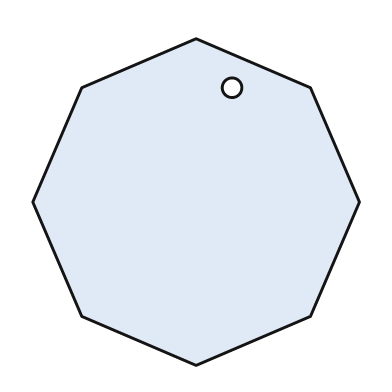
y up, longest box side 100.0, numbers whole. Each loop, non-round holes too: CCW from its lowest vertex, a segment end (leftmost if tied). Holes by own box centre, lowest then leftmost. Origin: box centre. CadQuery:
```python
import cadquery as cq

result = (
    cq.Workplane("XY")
    .moveTo(0.0, -50.0)
    .lineTo(35.0, -35.0)
    .lineTo(50.0, 0.0)
    .lineTo(35.0, 35.0)
    .lineTo(0.0, 50.0)
    .lineTo(-35.0, 35.0)
    .lineTo(-50.0, 0.0)
    .lineTo(-35.0, -35.0)
    .close()
    .moveTo(11.0, 35.0)
    .circle(3.0)
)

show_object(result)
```